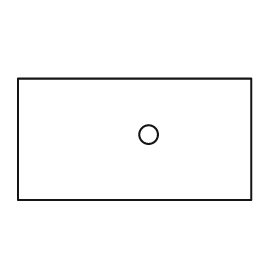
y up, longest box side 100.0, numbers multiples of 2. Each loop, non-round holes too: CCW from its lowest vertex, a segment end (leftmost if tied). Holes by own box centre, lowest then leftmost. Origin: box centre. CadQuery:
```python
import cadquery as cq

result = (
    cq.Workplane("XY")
    .moveTo(-50.0, -26.0)
    .lineTo(50.0, -26.0)
    .lineTo(50.0, 26.0)
    .lineTo(-50.0, 26.0)
    .close()
    .moveTo(6.0, 2.0)
    .circle(4.0)
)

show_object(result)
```